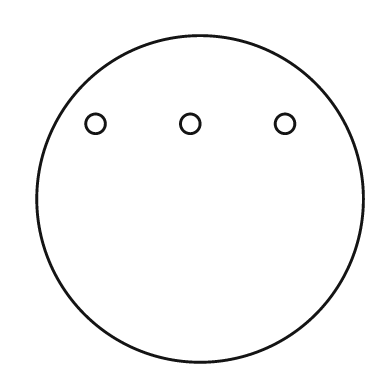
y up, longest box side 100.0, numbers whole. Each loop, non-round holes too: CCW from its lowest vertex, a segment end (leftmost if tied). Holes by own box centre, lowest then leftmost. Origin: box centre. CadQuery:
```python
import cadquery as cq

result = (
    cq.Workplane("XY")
    .moveTo(0.0, 0.0)
    .circle(50.0)
    .moveTo(-32.0, 23.0)
    .circle(3.0)
    .moveTo(-3.0, 23.0)
    .circle(3.0)
    .moveTo(26.0, 23.0)
    .circle(3.0)
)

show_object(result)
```